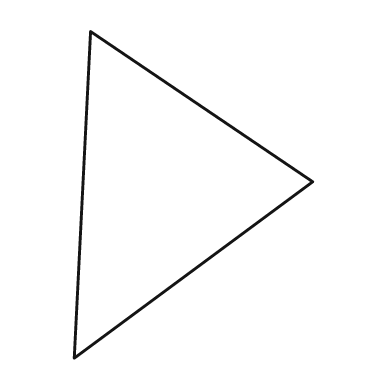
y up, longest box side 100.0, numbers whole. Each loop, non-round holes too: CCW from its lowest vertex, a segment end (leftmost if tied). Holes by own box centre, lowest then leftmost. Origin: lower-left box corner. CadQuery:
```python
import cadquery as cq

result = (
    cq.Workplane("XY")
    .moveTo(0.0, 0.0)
    .lineTo(73.0, 54.0)
    .lineTo(5.0, 100.0)
    .close()
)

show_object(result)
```